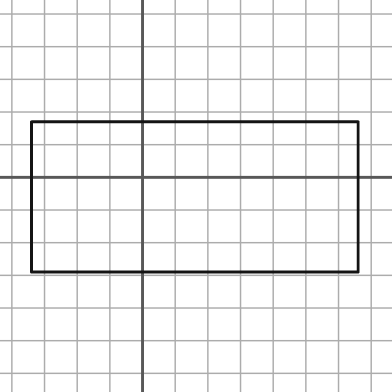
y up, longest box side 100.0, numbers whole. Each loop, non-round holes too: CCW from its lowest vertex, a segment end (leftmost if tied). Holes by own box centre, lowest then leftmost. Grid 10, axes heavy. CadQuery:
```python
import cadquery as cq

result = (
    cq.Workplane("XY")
    .moveTo(-34.0, -29.0)
    .lineTo(66.0, -29.0)
    .lineTo(66.0, 17.0)
    .lineTo(-34.0, 17.0)
    .close()
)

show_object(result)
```